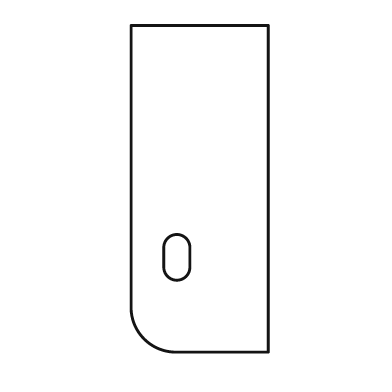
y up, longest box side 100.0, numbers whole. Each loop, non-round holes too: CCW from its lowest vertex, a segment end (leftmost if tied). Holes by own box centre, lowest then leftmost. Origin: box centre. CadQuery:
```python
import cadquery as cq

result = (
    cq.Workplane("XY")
    .moveTo(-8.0, -50.0)
    .lineTo(21.0, -50.0)
    .lineTo(21.0, 50.0)
    .lineTo(-21.0, 50.0)
    .lineTo(-21.0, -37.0)
    .threePointArc((-17.0, -46.0), (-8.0, -50.0))
    .close()
    .moveTo(-11.0, -24.0)
    .threePointArc((-7.0, -28.0), (-3.0, -24.0))
    .lineTo(-3.0, -18.0)
    .threePointArc((-7.0, -14.0), (-11.0, -18.0))
    .close()
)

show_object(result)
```